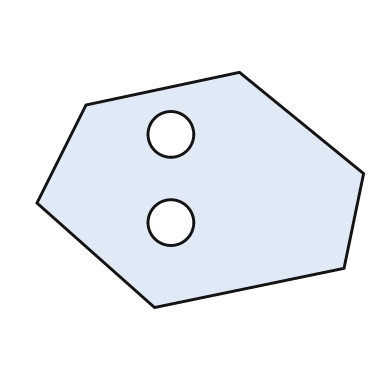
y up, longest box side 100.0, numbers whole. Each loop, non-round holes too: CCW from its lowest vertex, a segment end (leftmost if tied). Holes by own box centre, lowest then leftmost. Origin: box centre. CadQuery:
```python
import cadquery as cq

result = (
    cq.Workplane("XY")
    .moveTo(-14.0, -36.0)
    .lineTo(44.0, -24.0)
    .lineTo(50.0, 5.0)
    .lineTo(12.0, 36.0)
    .lineTo(-35.0, 26.0)
    .lineTo(-50.0, -4.0)
    .close()
    .moveTo(-9.0, -10.0)
    .circle(7.0)
    .moveTo(-9.0, 17.0)
    .circle(7.0)
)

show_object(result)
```